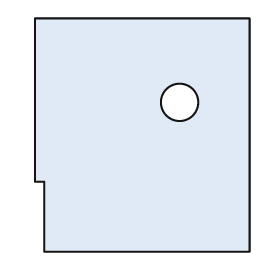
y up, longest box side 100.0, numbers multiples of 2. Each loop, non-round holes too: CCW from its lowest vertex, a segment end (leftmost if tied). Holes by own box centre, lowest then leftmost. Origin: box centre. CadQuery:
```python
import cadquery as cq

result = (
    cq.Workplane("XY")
    .moveTo(-42.0, -50.0)
    .lineTo(46.0, -50.0)
    .lineTo(46.0, 50.0)
    .lineTo(-46.0, 50.0)
    .lineTo(-46.0, -20.0)
    .lineTo(-42.0, -20.0)
    .close()
    .moveTo(16.0, 14.0)
    .circle(8.0)
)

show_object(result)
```